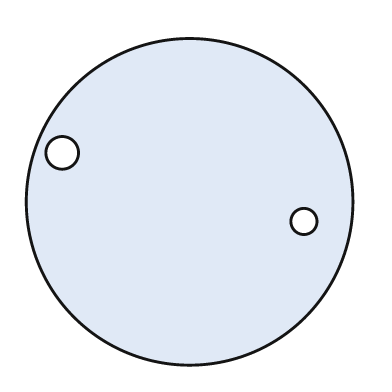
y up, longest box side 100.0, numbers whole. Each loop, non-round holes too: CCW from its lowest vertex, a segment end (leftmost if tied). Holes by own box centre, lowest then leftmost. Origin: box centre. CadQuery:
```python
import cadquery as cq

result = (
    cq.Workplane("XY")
    .moveTo(0.0, 0.0)
    .circle(50.0)
    .moveTo(35.0, -6.0)
    .circle(4.0)
    .moveTo(-39.0, 15.0)
    .circle(5.0)
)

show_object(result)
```